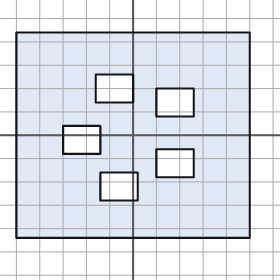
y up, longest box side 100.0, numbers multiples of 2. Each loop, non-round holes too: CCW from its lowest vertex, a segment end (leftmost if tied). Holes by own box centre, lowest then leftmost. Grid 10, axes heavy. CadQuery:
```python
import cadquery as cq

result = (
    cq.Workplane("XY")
    .moveTo(-50.0, -44.0)
    .lineTo(50.0, -44.0)
    .lineTo(50.0, 44.0)
    .lineTo(-50.0, 44.0)
    .close()
    .moveTo(-14.0, -28.0)
    .lineTo(2.0, -28.0)
    .lineTo(2.0, -16.0)
    .lineTo(-14.0, -16.0)
    .close()
    .moveTo(10.0, -18.0)
    .lineTo(26.0, -18.0)
    .lineTo(26.0, -6.0)
    .lineTo(10.0, -6.0)
    .close()
    .moveTo(-30.0, -8.0)
    .lineTo(-14.0, -8.0)
    .lineTo(-14.0, 4.0)
    .lineTo(-30.0, 4.0)
    .close()
    .moveTo(10.0, 8.0)
    .lineTo(26.0, 8.0)
    .lineTo(26.0, 20.0)
    .lineTo(10.0, 20.0)
    .close()
    .moveTo(-16.0, 14.0)
    .lineTo(0.0, 14.0)
    .lineTo(0.0, 26.0)
    .lineTo(-16.0, 26.0)
    .close()
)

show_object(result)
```